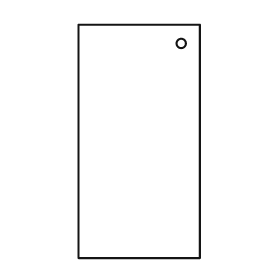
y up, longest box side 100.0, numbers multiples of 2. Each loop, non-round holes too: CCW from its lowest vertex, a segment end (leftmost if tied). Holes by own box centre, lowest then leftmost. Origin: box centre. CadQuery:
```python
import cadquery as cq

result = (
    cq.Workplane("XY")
    .moveTo(-26.0, -50.0)
    .lineTo(26.0, -50.0)
    .lineTo(26.0, 50.0)
    .lineTo(-26.0, 50.0)
    .close()
    .moveTo(18.0, 42.0)
    .circle(2.0)
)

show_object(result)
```